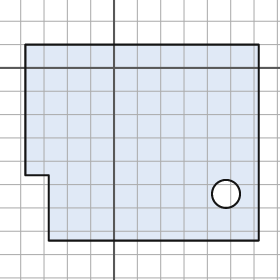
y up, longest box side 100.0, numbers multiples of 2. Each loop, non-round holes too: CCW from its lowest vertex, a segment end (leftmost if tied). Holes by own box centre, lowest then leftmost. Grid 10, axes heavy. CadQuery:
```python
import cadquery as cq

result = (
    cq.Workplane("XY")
    .moveTo(-28.0, -74.0)
    .lineTo(62.0, -74.0)
    .lineTo(62.0, 10.0)
    .lineTo(-38.0, 10.0)
    .lineTo(-38.0, -46.0)
    .lineTo(-28.0, -46.0)
    .close()
    .moveTo(48.0, -54.0)
    .circle(6.0)
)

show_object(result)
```